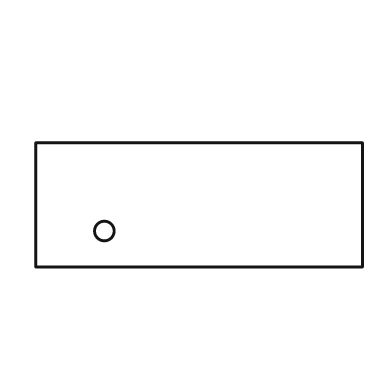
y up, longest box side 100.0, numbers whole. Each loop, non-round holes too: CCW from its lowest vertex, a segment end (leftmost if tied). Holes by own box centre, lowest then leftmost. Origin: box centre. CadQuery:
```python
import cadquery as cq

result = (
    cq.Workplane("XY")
    .moveTo(-50.0, -19.0)
    .lineTo(50.0, -19.0)
    .lineTo(50.0, 19.0)
    .lineTo(-50.0, 19.0)
    .close()
    .moveTo(-29.0, -8.0)
    .circle(3.0)
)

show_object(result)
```